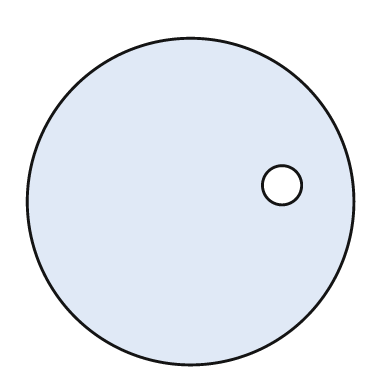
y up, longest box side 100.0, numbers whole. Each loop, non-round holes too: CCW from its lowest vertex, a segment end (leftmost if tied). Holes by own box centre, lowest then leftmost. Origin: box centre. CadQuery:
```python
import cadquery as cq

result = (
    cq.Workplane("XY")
    .moveTo(0.0, 0.0)
    .circle(50.0)
    .moveTo(28.0, 5.0)
    .circle(6.0)
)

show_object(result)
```